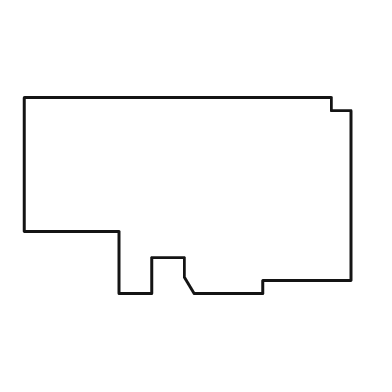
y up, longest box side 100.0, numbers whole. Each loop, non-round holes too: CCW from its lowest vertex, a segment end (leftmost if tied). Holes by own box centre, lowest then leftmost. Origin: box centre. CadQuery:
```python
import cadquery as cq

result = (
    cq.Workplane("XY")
    .moveTo(-21.0, -30.0)
    .lineTo(-11.0, -30.0)
    .lineTo(-11.0, -19.0)
    .lineTo(-1.0, -19.0)
    .lineTo(-1.0, -25.0)
    .lineTo(2.0, -30.0)
    .lineTo(23.0, -30.0)
    .lineTo(23.0, -26.0)
    .lineTo(50.0, -26.0)
    .lineTo(50.0, 26.0)
    .lineTo(44.0, 26.0)
    .lineTo(44.0, 30.0)
    .lineTo(-50.0, 30.0)
    .lineTo(-50.0, -11.0)
    .lineTo(-21.0, -11.0)
    .close()
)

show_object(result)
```